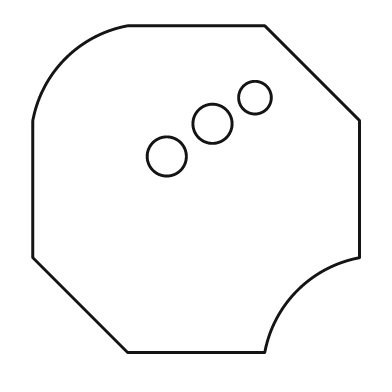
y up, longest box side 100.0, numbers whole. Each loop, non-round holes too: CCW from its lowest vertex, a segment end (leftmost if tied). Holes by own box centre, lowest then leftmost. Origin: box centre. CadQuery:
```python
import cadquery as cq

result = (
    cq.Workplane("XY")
    .moveTo(-21.0, -50.0)
    .lineTo(21.0, -50.0)
    .threePointArc((31.0, -31.0), (50.0, -21.0))
    .lineTo(50.0, 21.0)
    .lineTo(21.0, 50.0)
    .lineTo(-21.0, 50.0)
    .threePointArc((-40.0, 40.0), (-50.0, 21.0))
    .lineTo(-50.0, -21.0)
    .close()
    .moveTo(-9.0, 10.0)
    .circle(6.0)
    .moveTo(5.0, 20.0)
    .circle(6.0)
    .moveTo(18.0, 28.0)
    .circle(5.0)
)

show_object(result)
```